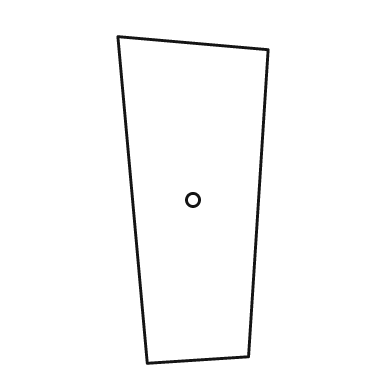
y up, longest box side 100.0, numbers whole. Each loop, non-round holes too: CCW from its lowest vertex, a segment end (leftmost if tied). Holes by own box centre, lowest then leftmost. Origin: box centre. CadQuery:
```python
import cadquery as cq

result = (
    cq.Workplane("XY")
    .moveTo(-14.0, -50.0)
    .lineTo(17.0, -48.0)
    .lineTo(23.0, 46.0)
    .lineTo(-23.0, 50.0)
    .close()
    .moveTo(0.0, 0.0)
    .circle(2.0)
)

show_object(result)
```